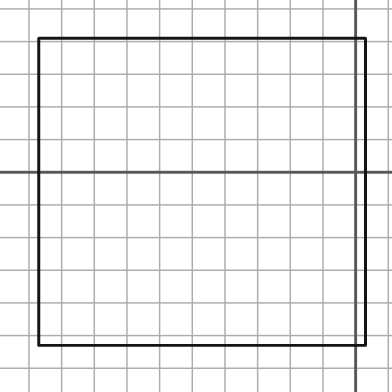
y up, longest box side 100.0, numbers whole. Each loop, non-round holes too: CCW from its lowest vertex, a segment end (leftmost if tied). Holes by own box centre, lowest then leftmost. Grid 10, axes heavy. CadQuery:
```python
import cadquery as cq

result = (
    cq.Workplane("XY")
    .moveTo(-97.0, -53.0)
    .lineTo(3.0, -53.0)
    .lineTo(3.0, 41.0)
    .lineTo(-97.0, 41.0)
    .close()
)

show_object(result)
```